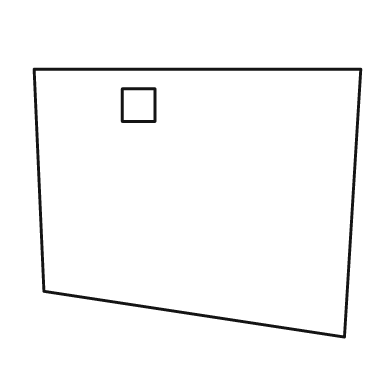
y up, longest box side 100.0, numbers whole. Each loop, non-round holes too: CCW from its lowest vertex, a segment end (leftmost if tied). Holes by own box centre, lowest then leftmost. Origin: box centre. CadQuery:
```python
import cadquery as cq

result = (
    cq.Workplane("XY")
    .moveTo(45.0, -41.0)
    .lineTo(50.0, 41.0)
    .lineTo(-50.0, 41.0)
    .lineTo(-47.0, -27.0)
    .close()
    .moveTo(-23.0, 25.0)
    .lineTo(-13.0, 25.0)
    .lineTo(-13.0, 35.0)
    .lineTo(-23.0, 35.0)
    .close()
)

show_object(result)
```